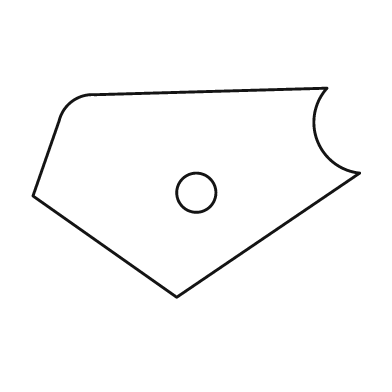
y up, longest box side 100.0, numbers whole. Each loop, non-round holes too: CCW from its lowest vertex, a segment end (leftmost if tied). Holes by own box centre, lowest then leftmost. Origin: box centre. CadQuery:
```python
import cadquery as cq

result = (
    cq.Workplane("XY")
    .moveTo(-6.0, -32.0)
    .lineTo(50.0, 6.0)
    .threePointArc((37.0, 16.0), (40.0, 32.0))
    .lineTo(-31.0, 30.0)
    .threePointArc((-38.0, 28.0), (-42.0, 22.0))
    .lineTo(-50.0, -1.0)
    .close()
    .moveTo(0.0, 0.0)
    .circle(6.0)
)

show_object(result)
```